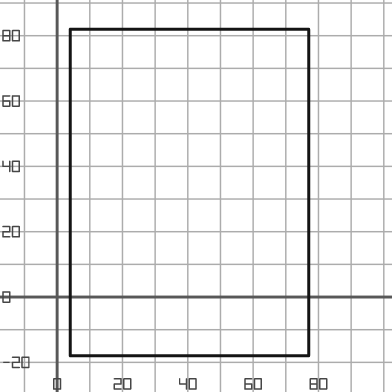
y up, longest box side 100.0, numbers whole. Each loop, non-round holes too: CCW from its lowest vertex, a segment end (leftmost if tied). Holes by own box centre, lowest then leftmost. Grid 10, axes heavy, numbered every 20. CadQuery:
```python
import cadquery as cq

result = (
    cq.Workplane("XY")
    .moveTo(4.0, -18.0)
    .lineTo(77.0, -18.0)
    .lineTo(77.0, 82.0)
    .lineTo(4.0, 82.0)
    .close()
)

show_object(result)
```